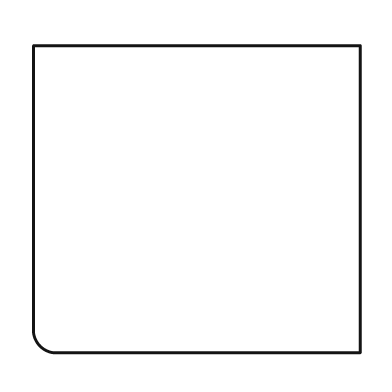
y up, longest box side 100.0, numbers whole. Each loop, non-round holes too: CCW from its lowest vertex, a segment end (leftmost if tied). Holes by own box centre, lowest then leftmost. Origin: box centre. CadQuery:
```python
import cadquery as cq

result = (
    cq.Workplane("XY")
    .moveTo(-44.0, -47.0)
    .lineTo(50.0, -47.0)
    .lineTo(50.0, 47.0)
    .lineTo(-50.0, 47.0)
    .lineTo(-50.0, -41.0)
    .threePointArc((-48.0, -45.0), (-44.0, -47.0))
    .close()
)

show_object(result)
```